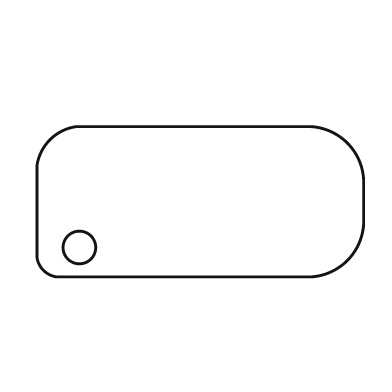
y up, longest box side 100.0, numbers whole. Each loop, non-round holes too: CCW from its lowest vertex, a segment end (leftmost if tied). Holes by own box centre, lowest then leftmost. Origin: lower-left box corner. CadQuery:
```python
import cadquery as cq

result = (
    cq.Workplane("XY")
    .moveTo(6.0, 0.0)
    .lineTo(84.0, 0.0)
    .threePointArc((95.0, 5.0), (100.0, 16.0))
    .lineTo(100.0, 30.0)
    .threePointArc((95.0, 41.0), (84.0, 46.0))
    .lineTo(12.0, 46.0)
    .threePointArc((4.0, 42.0), (0.0, 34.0))
    .lineTo(0.0, 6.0)
    .threePointArc((2.0, 2.0), (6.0, 0.0))
    .close()
    .moveTo(13.0, 9.0)
    .circle(5.0)
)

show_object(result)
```